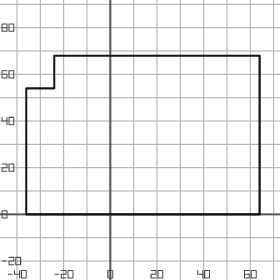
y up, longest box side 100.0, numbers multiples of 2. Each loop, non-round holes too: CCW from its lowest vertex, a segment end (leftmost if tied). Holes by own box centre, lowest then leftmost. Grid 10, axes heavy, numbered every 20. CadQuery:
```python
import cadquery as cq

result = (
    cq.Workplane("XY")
    .moveTo(-36.0, 0.0)
    .lineTo(64.0, 0.0)
    .lineTo(64.0, 68.0)
    .lineTo(-24.0, 68.0)
    .lineTo(-24.0, 54.0)
    .lineTo(-36.0, 54.0)
    .close()
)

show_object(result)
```